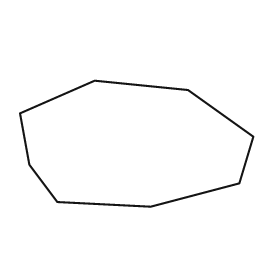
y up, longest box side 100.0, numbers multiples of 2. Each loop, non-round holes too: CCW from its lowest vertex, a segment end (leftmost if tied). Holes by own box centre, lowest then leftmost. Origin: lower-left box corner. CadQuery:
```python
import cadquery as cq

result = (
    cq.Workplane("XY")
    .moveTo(56.0, 0.0)
    .lineTo(94.0, 10.0)
    .lineTo(100.0, 30.0)
    .lineTo(72.0, 50.0)
    .lineTo(32.0, 54.0)
    .lineTo(0.0, 40.0)
    .lineTo(4.0, 18.0)
    .lineTo(16.0, 2.0)
    .close()
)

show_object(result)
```